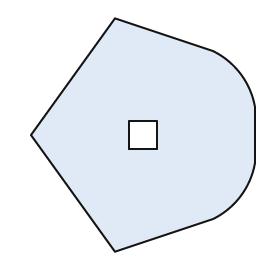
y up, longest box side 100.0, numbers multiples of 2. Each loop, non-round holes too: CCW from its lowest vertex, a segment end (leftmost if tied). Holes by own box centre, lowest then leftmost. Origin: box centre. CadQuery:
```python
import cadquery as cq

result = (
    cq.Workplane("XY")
    .moveTo(-12.0, -50.0)
    .lineTo(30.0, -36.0)
    .threePointArc((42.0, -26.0), (48.0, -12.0))
    .lineTo(48.0, 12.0)
    .threePointArc((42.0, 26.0), (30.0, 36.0))
    .lineTo(-12.0, 50.0)
    .lineTo(-48.0, 0.0)
    .close()
    .moveTo(-6.0, -6.0)
    .lineTo(6.0, -6.0)
    .lineTo(6.0, 6.0)
    .lineTo(-6.0, 6.0)
    .close()
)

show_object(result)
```